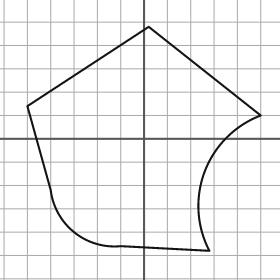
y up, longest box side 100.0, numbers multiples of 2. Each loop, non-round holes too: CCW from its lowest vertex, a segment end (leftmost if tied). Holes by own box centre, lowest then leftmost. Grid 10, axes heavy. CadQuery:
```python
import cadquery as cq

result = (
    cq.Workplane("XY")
    .moveTo(28.0, -48.0)
    .threePointArc((26.0, -14.0), (50.0, 10.0))
    .lineTo(2.0, 48.0)
    .lineTo(-50.0, 14.0)
    .lineTo(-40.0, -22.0)
    .threePointArc((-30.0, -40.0), (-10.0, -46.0))
    .close()
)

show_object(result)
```